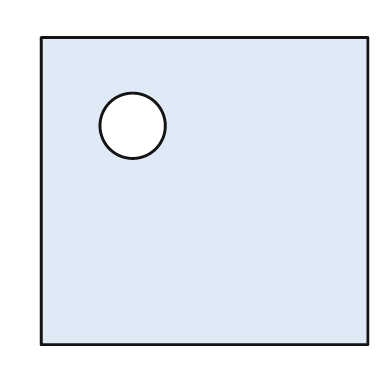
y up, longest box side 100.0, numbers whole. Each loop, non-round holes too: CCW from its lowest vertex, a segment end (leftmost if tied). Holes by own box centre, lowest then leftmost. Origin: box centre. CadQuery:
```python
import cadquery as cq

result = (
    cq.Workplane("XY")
    .moveTo(-50.0, -47.0)
    .lineTo(50.0, -47.0)
    .lineTo(50.0, 47.0)
    .lineTo(-50.0, 47.0)
    .close()
    .moveTo(-22.0, 20.0)
    .circle(10.0)
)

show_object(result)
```